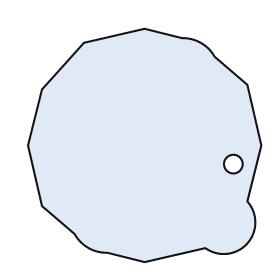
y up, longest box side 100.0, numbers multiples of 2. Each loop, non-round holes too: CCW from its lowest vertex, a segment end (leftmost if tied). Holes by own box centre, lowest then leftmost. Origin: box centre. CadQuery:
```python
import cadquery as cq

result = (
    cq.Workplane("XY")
    .moveTo(0.0, -50.0)
    .lineTo(26.0, -44.0)
    .threePointArc((44.0, -42.0), (44.0, -24.0))
    .lineTo(50.0, 0.0)
    .lineTo(44.0, 26.0)
    .lineTo(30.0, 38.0)
    .threePointArc((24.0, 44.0), (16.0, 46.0))
    .lineTo(0.0, 50.0)
    .lineTo(-26.0, 44.0)
    .lineTo(-44.0, 24.0)
    .lineTo(-50.0, 0.0)
    .lineTo(-44.0, -26.0)
    .lineTo(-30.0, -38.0)
    .threePointArc((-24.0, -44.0), (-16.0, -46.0))
    .close()
    .moveTo(38.0, -8.0)
    .circle(4.0)
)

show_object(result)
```